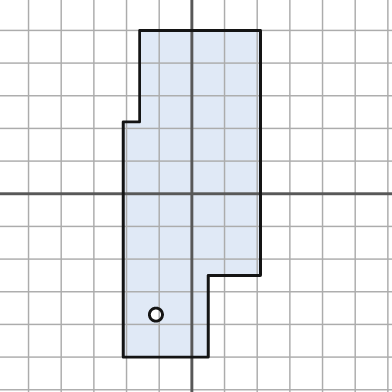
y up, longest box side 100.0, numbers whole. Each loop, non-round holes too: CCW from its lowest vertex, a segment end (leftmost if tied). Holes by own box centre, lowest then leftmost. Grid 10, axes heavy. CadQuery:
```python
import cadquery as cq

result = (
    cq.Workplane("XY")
    .moveTo(-21.0, -50.0)
    .lineTo(5.0, -50.0)
    .lineTo(5.0, -25.0)
    .lineTo(21.0, -25.0)
    .lineTo(21.0, 50.0)
    .lineTo(-16.0, 50.0)
    .lineTo(-16.0, 22.0)
    .lineTo(-21.0, 22.0)
    .close()
    .moveTo(-11.0, -37.0)
    .circle(2.0)
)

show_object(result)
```